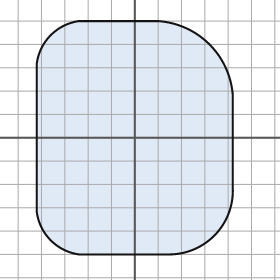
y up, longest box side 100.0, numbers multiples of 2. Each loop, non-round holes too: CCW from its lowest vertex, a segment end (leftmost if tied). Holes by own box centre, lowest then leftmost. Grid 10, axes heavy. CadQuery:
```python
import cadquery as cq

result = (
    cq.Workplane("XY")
    .moveTo(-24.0, -50.0)
    .lineTo(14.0, -50.0)
    .threePointArc((34.0, -42.0), (42.0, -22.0))
    .lineTo(42.0, 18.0)
    .threePointArc((32.0, 40.0), (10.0, 50.0))
    .lineTo(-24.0, 50.0)
    .threePointArc((-36.0, 44.0), (-42.0, 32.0))
    .lineTo(-42.0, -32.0)
    .threePointArc((-36.0, -44.0), (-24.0, -50.0))
    .close()
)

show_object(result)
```